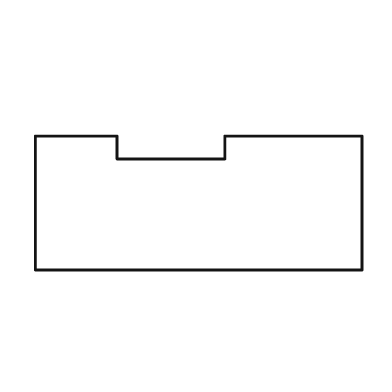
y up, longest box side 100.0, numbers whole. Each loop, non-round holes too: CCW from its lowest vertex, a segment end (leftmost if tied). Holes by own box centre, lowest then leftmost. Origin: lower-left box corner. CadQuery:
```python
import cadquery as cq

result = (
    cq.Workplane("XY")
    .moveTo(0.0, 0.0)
    .lineTo(100.0, 0.0)
    .lineTo(100.0, 41.0)
    .lineTo(58.0, 41.0)
    .lineTo(58.0, 34.0)
    .lineTo(25.0, 34.0)
    .lineTo(25.0, 41.0)
    .lineTo(0.0, 41.0)
    .close()
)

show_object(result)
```